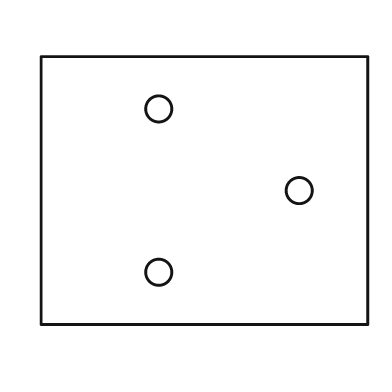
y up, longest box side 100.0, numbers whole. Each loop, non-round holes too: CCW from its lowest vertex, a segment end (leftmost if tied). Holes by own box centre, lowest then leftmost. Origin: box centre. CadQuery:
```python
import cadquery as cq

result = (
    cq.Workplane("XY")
    .moveTo(-50.0, -41.0)
    .lineTo(50.0, -41.0)
    .lineTo(50.0, 41.0)
    .lineTo(-50.0, 41.0)
    .close()
    .moveTo(-14.0, -25.0)
    .circle(4.0)
    .moveTo(29.0, 0.0)
    .circle(4.0)
    .moveTo(-14.0, 25.0)
    .circle(4.0)
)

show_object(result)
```